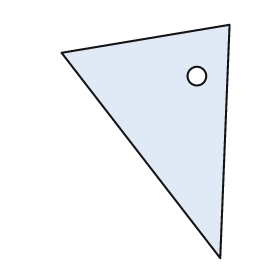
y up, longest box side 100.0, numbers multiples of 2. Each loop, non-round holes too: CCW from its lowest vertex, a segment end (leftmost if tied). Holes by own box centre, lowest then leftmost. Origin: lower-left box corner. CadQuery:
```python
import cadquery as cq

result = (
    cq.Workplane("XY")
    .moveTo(68.0, 0.0)
    .lineTo(72.0, 100.0)
    .lineTo(0.0, 88.0)
    .close()
    .moveTo(58.0, 78.0)
    .circle(4.0)
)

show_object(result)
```